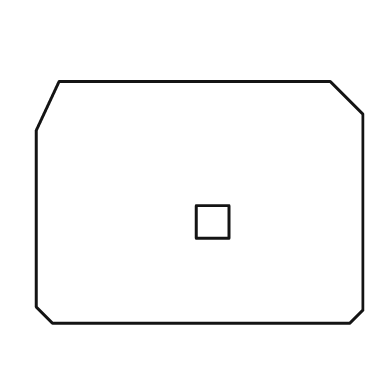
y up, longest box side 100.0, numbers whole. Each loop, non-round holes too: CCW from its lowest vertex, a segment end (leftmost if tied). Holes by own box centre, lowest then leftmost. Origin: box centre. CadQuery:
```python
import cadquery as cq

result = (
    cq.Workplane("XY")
    .moveTo(-45.0, -37.0)
    .lineTo(46.0, -37.0)
    .lineTo(50.0, -33.0)
    .lineTo(50.0, 27.0)
    .lineTo(40.0, 37.0)
    .lineTo(-43.0, 37.0)
    .lineTo(-50.0, 22.0)
    .lineTo(-50.0, -32.0)
    .close()
    .moveTo(-1.0, -11.0)
    .lineTo(9.0, -11.0)
    .lineTo(9.0, -1.0)
    .lineTo(-1.0, -1.0)
    .close()
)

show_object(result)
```